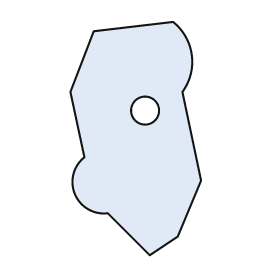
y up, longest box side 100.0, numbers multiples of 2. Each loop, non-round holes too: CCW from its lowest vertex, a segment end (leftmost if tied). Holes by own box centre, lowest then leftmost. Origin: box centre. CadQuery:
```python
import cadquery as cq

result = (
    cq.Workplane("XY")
    .moveTo(6.0, -50.0)
    .lineTo(18.0, -42.0)
    .lineTo(28.0, -18.0)
    .lineTo(20.0, 20.0)
    .threePointArc((24.0, 36.0), (16.0, 50.0))
    .lineTo(-18.0, 46.0)
    .lineTo(-28.0, 20.0)
    .lineTo(-22.0, -8.0)
    .threePointArc((-26.0, -24.0), (-12.0, -32.0))
    .close()
    .moveTo(4.0, 12.0)
    .circle(6.0)
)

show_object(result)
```